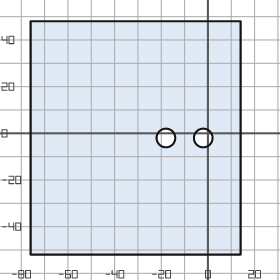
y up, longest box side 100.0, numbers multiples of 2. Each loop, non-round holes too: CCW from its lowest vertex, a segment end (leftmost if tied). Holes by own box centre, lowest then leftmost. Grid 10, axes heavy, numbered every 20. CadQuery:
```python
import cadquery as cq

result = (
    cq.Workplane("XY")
    .moveTo(-76.0, -52.0)
    .lineTo(14.0, -52.0)
    .lineTo(14.0, 48.0)
    .lineTo(-76.0, 48.0)
    .close()
    .moveTo(-18.0, -2.0)
    .circle(4.0)
    .moveTo(-2.0, -2.0)
    .circle(4.0)
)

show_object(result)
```